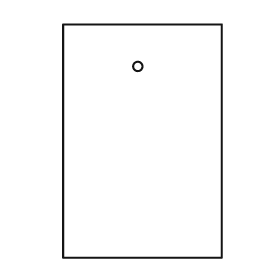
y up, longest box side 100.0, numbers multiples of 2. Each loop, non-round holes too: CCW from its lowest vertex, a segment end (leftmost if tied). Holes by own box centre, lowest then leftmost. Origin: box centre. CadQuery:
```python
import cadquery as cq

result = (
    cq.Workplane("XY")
    .moveTo(-34.0, -50.0)
    .lineTo(34.0, -50.0)
    .lineTo(34.0, 50.0)
    .lineTo(-34.0, 50.0)
    .close()
    .moveTo(-2.0, 32.0)
    .circle(2.0)
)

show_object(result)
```